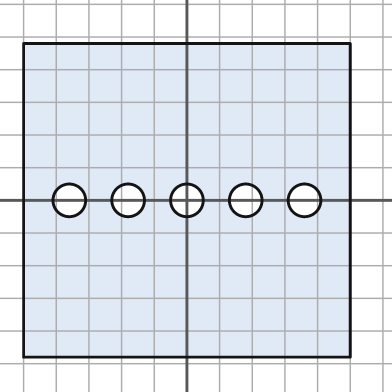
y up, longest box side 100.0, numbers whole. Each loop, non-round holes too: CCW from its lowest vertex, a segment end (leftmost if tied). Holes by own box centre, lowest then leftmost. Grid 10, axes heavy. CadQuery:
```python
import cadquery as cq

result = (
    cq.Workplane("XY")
    .moveTo(-50.0, -48.0)
    .lineTo(50.0, -48.0)
    .lineTo(50.0, 48.0)
    .lineTo(-50.0, 48.0)
    .close()
    .moveTo(-36.0, 0.0)
    .circle(5.0)
    .moveTo(-18.0, 0.0)
    .circle(5.0)
    .moveTo(0.0, 0.0)
    .circle(5.0)
    .moveTo(18.0, 0.0)
    .circle(5.0)
    .moveTo(36.0, 0.0)
    .circle(5.0)
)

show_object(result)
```